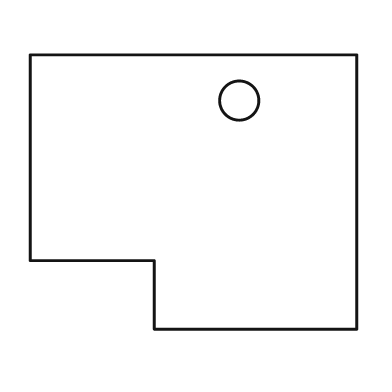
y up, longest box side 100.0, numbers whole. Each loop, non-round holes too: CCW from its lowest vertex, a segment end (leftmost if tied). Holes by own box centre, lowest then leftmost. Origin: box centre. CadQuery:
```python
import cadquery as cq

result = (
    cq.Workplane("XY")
    .moveTo(-12.0, -42.0)
    .lineTo(50.0, -42.0)
    .lineTo(50.0, 42.0)
    .lineTo(-50.0, 42.0)
    .lineTo(-50.0, -21.0)
    .lineTo(-12.0, -21.0)
    .close()
    .moveTo(14.0, 28.0)
    .circle(6.0)
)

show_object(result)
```